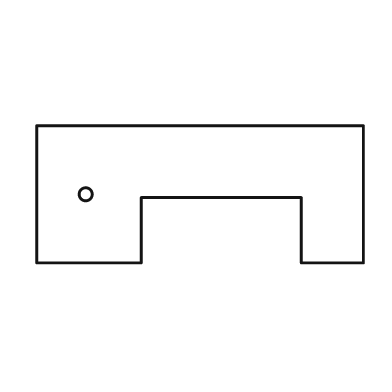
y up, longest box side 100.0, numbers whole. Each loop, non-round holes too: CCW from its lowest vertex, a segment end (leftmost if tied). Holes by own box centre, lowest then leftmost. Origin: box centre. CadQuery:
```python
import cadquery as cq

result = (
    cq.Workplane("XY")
    .moveTo(-50.0, -21.0)
    .lineTo(-18.0, -21.0)
    .lineTo(-18.0, -1.0)
    .lineTo(31.0, -1.0)
    .lineTo(31.0, -21.0)
    .lineTo(50.0, -21.0)
    .lineTo(50.0, 21.0)
    .lineTo(-50.0, 21.0)
    .close()
    .moveTo(-35.0, 0.0)
    .circle(2.0)
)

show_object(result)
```